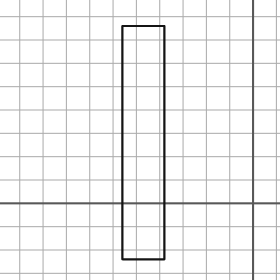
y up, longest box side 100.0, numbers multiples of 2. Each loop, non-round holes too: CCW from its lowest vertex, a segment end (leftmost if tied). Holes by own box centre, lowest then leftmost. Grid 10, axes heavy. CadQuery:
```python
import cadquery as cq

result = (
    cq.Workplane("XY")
    .moveTo(-56.0, -24.0)
    .lineTo(-38.0, -24.0)
    .lineTo(-38.0, 76.0)
    .lineTo(-56.0, 76.0)
    .close()
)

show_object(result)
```